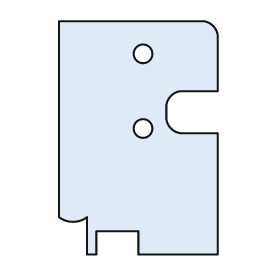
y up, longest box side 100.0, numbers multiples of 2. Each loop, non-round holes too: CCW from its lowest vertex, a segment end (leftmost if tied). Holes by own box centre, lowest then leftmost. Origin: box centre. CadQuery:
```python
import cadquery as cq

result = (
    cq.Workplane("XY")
    .moveTo(-22.0, -50.0)
    .lineTo(-18.0, -50.0)
    .lineTo(-18.0, -40.0)
    .lineTo(0.0, -40.0)
    .lineTo(0.0, -50.0)
    .lineTo(34.0, -50.0)
    .lineTo(34.0, 2.0)
    .lineTo(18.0, 2.0)
    .threePointArc((14.0, 4.0), (12.0, 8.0))
    .lineTo(12.0, 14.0)
    .threePointArc((14.0, 18.0), (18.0, 20.0))
    .lineTo(34.0, 20.0)
    .lineTo(34.0, 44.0)
    .threePointArc((32.0, 48.0), (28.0, 50.0))
    .lineTo(-34.0, 50.0)
    .lineTo(-34.0, -34.0)
    .threePointArc((-28.0, -36.0), (-22.0, -34.0))
    .close()
    .moveTo(2.0, 4.0)
    .circle(4.0)
    .moveTo(2.0, 36.0)
    .circle(4.0)
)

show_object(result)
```